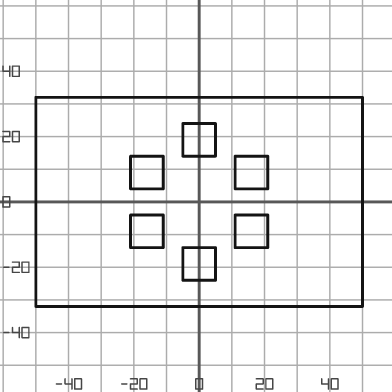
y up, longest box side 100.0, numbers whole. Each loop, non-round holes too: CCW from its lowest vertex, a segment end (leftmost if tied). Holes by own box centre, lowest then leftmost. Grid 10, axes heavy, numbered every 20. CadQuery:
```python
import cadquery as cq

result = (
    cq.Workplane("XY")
    .moveTo(-50.0, -32.0)
    .lineTo(50.0, -32.0)
    .lineTo(50.0, 32.0)
    .lineTo(-50.0, 32.0)
    .close()
    .moveTo(-5.0, -24.0)
    .lineTo(5.0, -24.0)
    .lineTo(5.0, -14.0)
    .lineTo(-5.0, -14.0)
    .close()
    .moveTo(-21.0, -14.0)
    .lineTo(-11.0, -14.0)
    .lineTo(-11.0, -4.0)
    .lineTo(-21.0, -4.0)
    .close()
    .moveTo(11.0, -14.0)
    .lineTo(21.0, -14.0)
    .lineTo(21.0, -4.0)
    .lineTo(11.0, -4.0)
    .close()
    .moveTo(-21.0, 4.0)
    .lineTo(-11.0, 4.0)
    .lineTo(-11.0, 14.0)
    .lineTo(-21.0, 14.0)
    .close()
    .moveTo(11.0, 4.0)
    .lineTo(21.0, 4.0)
    .lineTo(21.0, 14.0)
    .lineTo(11.0, 14.0)
    .close()
    .moveTo(-5.0, 14.0)
    .lineTo(5.0, 14.0)
    .lineTo(5.0, 24.0)
    .lineTo(-5.0, 24.0)
    .close()
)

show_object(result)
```